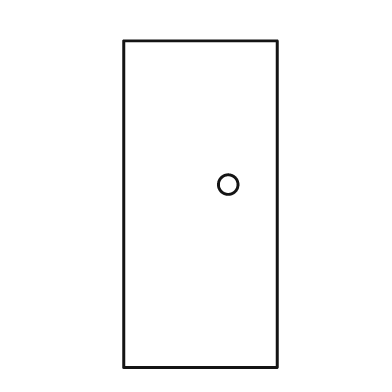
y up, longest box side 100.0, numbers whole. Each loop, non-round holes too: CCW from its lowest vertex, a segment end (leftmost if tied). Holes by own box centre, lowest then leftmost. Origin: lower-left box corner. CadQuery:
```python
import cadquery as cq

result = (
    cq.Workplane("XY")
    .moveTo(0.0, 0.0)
    .lineTo(47.0, 0.0)
    .lineTo(47.0, 100.0)
    .lineTo(0.0, 100.0)
    .close()
    .moveTo(32.0, 56.0)
    .circle(3.0)
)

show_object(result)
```